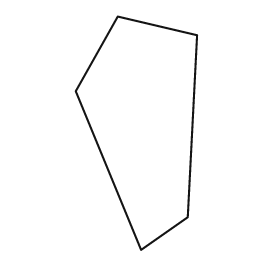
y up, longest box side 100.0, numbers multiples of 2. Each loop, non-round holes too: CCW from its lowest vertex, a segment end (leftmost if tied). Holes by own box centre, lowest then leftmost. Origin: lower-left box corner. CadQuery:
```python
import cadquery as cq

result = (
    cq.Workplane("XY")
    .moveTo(28.0, 0.0)
    .lineTo(48.0, 14.0)
    .lineTo(52.0, 92.0)
    .lineTo(18.0, 100.0)
    .lineTo(0.0, 68.0)
    .close()
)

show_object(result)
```